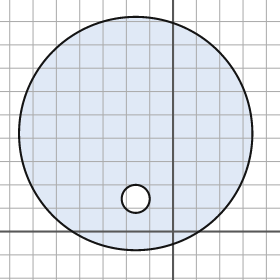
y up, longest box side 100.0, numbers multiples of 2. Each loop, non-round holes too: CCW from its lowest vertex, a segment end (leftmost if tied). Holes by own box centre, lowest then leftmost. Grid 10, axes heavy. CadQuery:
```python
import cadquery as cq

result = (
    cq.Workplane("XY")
    .moveTo(-16.0, 42.0)
    .circle(50.0)
    .moveTo(-16.0, 14.0)
    .circle(6.0)
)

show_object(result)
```